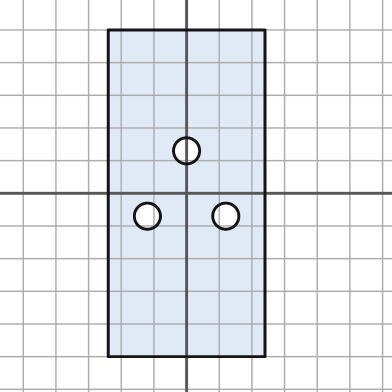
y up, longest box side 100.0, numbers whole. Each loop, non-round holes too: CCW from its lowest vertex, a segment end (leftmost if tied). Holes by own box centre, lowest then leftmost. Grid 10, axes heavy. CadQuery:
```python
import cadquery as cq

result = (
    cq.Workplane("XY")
    .moveTo(-24.0, -50.0)
    .lineTo(24.0, -50.0)
    .lineTo(24.0, 50.0)
    .lineTo(-24.0, 50.0)
    .close()
    .moveTo(-12.0, -7.0)
    .circle(4.0)
    .moveTo(12.0, -7.0)
    .circle(4.0)
    .moveTo(0.0, 13.0)
    .circle(4.0)
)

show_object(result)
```